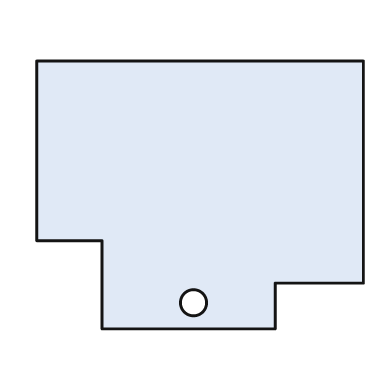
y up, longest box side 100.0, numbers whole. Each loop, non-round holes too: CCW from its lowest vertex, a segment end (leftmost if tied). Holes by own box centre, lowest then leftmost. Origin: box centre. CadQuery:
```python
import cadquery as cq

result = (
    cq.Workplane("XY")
    .moveTo(-30.0, -41.0)
    .lineTo(23.0, -41.0)
    .lineTo(23.0, -27.0)
    .lineTo(50.0, -27.0)
    .lineTo(50.0, 41.0)
    .lineTo(-50.0, 41.0)
    .lineTo(-50.0, -14.0)
    .lineTo(-30.0, -14.0)
    .close()
    .moveTo(-2.0, -33.0)
    .circle(4.0)
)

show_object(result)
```